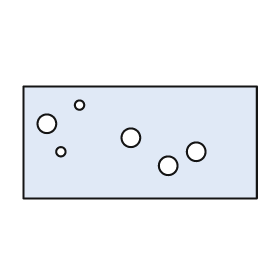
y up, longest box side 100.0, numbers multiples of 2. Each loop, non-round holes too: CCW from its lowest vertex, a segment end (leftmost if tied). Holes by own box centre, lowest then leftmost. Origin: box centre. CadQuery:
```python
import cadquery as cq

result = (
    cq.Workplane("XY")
    .moveTo(-50.0, -24.0)
    .lineTo(50.0, -24.0)
    .lineTo(50.0, 24.0)
    .lineTo(-50.0, 24.0)
    .close()
    .moveTo(12.0, -10.0)
    .circle(4.0)
    .moveTo(-34.0, -4.0)
    .circle(2.0)
    .moveTo(24.0, -4.0)
    .circle(4.0)
    .moveTo(-4.0, 2.0)
    .circle(4.0)
    .moveTo(-40.0, 8.0)
    .circle(4.0)
    .moveTo(-26.0, 16.0)
    .circle(2.0)
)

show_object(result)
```